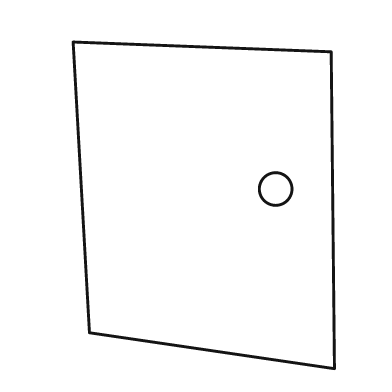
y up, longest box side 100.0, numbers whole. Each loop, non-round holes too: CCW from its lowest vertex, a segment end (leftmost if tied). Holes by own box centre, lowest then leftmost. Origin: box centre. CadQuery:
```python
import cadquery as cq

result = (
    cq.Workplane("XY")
    .moveTo(40.0, -50.0)
    .lineTo(39.0, 47.0)
    .lineTo(-40.0, 50.0)
    .lineTo(-35.0, -39.0)
    .close()
    .moveTo(22.0, 5.0)
    .circle(5.0)
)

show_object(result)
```